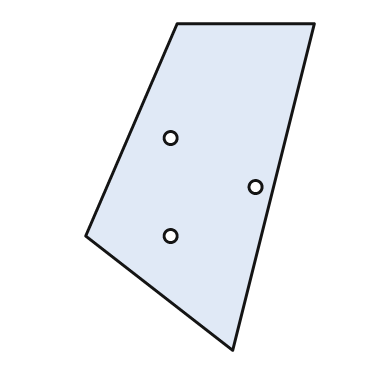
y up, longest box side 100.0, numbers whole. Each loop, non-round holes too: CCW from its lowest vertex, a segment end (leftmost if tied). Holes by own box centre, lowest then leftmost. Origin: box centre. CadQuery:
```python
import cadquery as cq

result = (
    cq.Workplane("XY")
    .moveTo(10.0, -50.0)
    .lineTo(35.0, 50.0)
    .lineTo(-7.0, 50.0)
    .lineTo(-35.0, -15.0)
    .close()
    .moveTo(-9.0, -15.0)
    .circle(2.0)
    .moveTo(17.0, 0.0)
    .circle(2.0)
    .moveTo(-9.0, 15.0)
    .circle(2.0)
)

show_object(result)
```